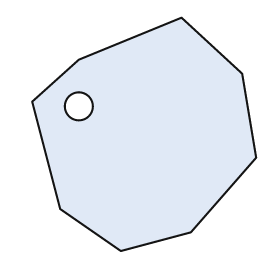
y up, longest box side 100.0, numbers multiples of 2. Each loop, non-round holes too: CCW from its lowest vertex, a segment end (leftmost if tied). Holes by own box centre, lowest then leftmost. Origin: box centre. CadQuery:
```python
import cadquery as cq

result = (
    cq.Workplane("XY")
    .moveTo(-10.0, -50.0)
    .lineTo(20.0, -42.0)
    .lineTo(48.0, -10.0)
    .lineTo(42.0, 26.0)
    .lineTo(16.0, 50.0)
    .lineTo(-28.0, 32.0)
    .lineTo(-48.0, 14.0)
    .lineTo(-36.0, -32.0)
    .close()
    .moveTo(-28.0, 12.0)
    .circle(6.0)
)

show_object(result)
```